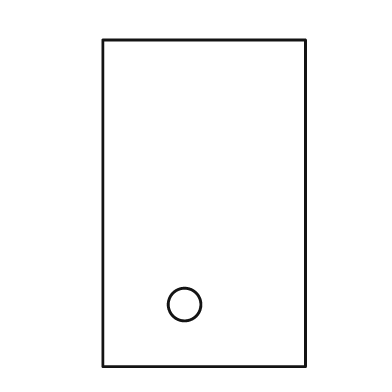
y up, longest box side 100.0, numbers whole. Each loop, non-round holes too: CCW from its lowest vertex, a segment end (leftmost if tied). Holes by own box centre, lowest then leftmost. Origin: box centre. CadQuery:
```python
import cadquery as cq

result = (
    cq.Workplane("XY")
    .moveTo(-31.0, -50.0)
    .lineTo(31.0, -50.0)
    .lineTo(31.0, 50.0)
    .lineTo(-31.0, 50.0)
    .close()
    .moveTo(-6.0, -31.0)
    .circle(5.0)
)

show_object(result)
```